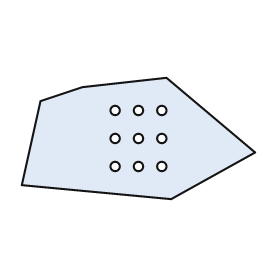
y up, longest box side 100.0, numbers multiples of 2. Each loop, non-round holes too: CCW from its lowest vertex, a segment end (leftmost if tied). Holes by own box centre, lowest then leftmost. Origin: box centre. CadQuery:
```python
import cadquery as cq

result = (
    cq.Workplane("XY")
    .moveTo(14.0, -26.0)
    .lineTo(50.0, -6.0)
    .lineTo(12.0, 26.0)
    .lineTo(-24.0, 22.0)
    .lineTo(-42.0, 16.0)
    .lineTo(-50.0, -20.0)
    .close()
    .moveTo(-10.0, -12.0)
    .circle(2.0)
    .moveTo(0.0, -12.0)
    .circle(2.0)
    .moveTo(10.0, -12.0)
    .circle(2.0)
    .moveTo(-10.0, 0.0)
    .circle(2.0)
    .moveTo(0.0, 0.0)
    .circle(2.0)
    .moveTo(10.0, 0.0)
    .circle(2.0)
    .moveTo(-10.0, 12.0)
    .circle(2.0)
    .moveTo(0.0, 12.0)
    .circle(2.0)
    .moveTo(10.0, 12.0)
    .circle(2.0)
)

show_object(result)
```